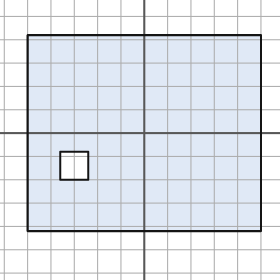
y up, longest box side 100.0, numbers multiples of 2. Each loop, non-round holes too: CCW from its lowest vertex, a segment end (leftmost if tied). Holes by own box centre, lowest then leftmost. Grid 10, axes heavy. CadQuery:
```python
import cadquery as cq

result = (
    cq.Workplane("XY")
    .moveTo(-50.0, -42.0)
    .lineTo(50.0, -42.0)
    .lineTo(50.0, 42.0)
    .lineTo(-50.0, 42.0)
    .close()
    .moveTo(-36.0, -20.0)
    .lineTo(-24.0, -20.0)
    .lineTo(-24.0, -8.0)
    .lineTo(-36.0, -8.0)
    .close()
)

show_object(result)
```